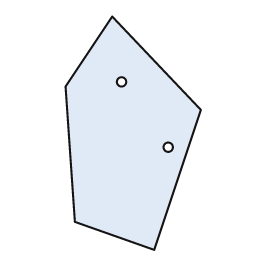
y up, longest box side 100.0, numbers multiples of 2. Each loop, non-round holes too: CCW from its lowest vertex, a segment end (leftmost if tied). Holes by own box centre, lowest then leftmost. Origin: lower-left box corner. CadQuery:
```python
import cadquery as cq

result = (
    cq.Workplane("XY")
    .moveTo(38.0, 0.0)
    .lineTo(58.0, 60.0)
    .lineTo(20.0, 100.0)
    .lineTo(0.0, 70.0)
    .lineTo(4.0, 12.0)
    .close()
    .moveTo(44.0, 44.0)
    .circle(2.0)
    .moveTo(24.0, 72.0)
    .circle(2.0)
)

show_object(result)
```